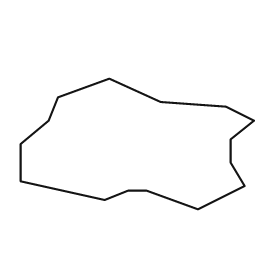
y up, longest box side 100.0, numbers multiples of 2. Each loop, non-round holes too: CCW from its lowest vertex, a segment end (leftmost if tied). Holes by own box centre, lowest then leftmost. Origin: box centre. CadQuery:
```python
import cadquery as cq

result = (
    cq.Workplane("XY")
    .moveTo(26.0, -28.0)
    .lineTo(46.0, -18.0)
    .lineTo(40.0, -8.0)
    .lineTo(40.0, 2.0)
    .lineTo(50.0, 10.0)
    .lineTo(38.0, 16.0)
    .lineTo(10.0, 18.0)
    .lineTo(-12.0, 28.0)
    .lineTo(-34.0, 20.0)
    .lineTo(-38.0, 10.0)
    .lineTo(-50.0, 0.0)
    .lineTo(-50.0, -16.0)
    .lineTo(-14.0, -24.0)
    .lineTo(-4.0, -20.0)
    .lineTo(4.0, -20.0)
    .close()
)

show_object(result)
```